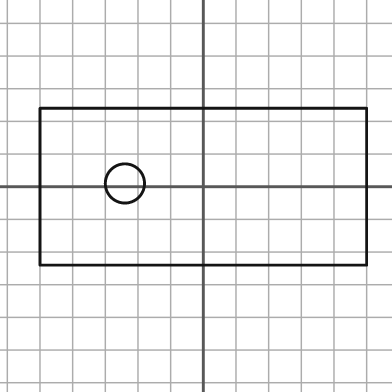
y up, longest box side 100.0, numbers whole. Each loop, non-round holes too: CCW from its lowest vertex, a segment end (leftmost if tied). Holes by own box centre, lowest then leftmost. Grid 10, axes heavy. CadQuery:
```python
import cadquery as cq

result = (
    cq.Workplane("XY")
    .moveTo(-50.0, -24.0)
    .lineTo(50.0, -24.0)
    .lineTo(50.0, 24.0)
    .lineTo(-50.0, 24.0)
    .close()
    .moveTo(-24.0, 1.0)
    .circle(6.0)
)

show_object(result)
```